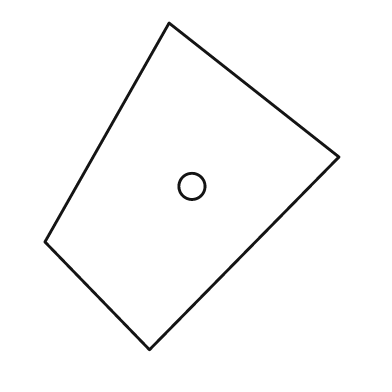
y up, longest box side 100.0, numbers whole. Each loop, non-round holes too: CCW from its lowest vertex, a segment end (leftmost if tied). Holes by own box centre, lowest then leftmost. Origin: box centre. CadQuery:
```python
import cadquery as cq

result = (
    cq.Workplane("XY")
    .moveTo(-13.0, -50.0)
    .lineTo(45.0, 9.0)
    .lineTo(-7.0, 50.0)
    .lineTo(-45.0, -17.0)
    .close()
    .moveTo(0.0, 0.0)
    .circle(4.0)
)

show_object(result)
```